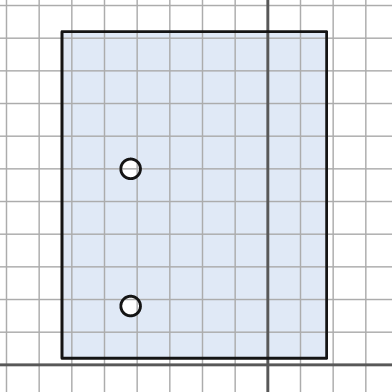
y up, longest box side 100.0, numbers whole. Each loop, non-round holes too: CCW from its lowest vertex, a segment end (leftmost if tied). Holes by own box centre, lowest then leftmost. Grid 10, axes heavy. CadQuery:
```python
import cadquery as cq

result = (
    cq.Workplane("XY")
    .moveTo(-63.0, 2.0)
    .lineTo(18.0, 2.0)
    .lineTo(18.0, 102.0)
    .lineTo(-63.0, 102.0)
    .close()
    .moveTo(-42.0, 18.0)
    .circle(3.0)
    .moveTo(-42.0, 60.0)
    .circle(3.0)
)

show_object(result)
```